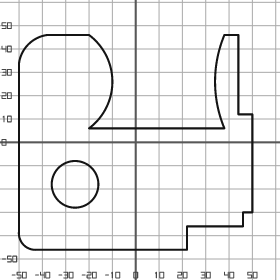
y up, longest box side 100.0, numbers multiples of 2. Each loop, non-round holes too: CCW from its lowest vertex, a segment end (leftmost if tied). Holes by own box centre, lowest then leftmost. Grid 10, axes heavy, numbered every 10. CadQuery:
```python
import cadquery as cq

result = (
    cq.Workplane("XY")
    .moveTo(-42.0, -46.0)
    .lineTo(22.0, -46.0)
    .lineTo(22.0, -36.0)
    .lineTo(46.0, -36.0)
    .lineTo(46.0, -30.0)
    .lineTo(50.0, -30.0)
    .lineTo(50.0, 12.0)
    .lineTo(44.0, 12.0)
    .lineTo(44.0, 46.0)
    .lineTo(38.0, 46.0)
    .threePointArc((34.0, 26.0), (38.0, 6.0))
    .lineTo(-20.0, 6.0)
    .threePointArc((-10.0, 26.0), (-20.0, 46.0))
    .lineTo(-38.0, 46.0)
    .threePointArc((-46.0, 42.0), (-50.0, 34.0))
    .lineTo(-50.0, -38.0)
    .threePointArc((-48.0, -44.0), (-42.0, -46.0))
    .close()
    .moveTo(-26.0, -18.0)
    .circle(10.0)
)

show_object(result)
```